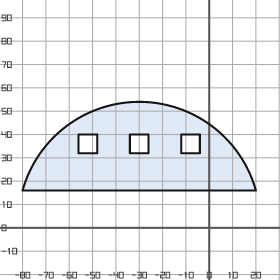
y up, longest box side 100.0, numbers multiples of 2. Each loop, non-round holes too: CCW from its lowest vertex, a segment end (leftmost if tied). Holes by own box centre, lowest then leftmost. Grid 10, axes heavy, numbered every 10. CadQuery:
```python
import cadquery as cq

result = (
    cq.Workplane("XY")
    .moveTo(-80.0, 16.0)
    .lineTo(20.0, 16.0)
    .threePointArc((-30.0, 54.0), (-80.0, 16.0))
    .close()
    .moveTo(-56.0, 32.0)
    .lineTo(-48.0, 32.0)
    .lineTo(-48.0, 40.0)
    .lineTo(-56.0, 40.0)
    .close()
    .moveTo(-34.0, 32.0)
    .lineTo(-26.0, 32.0)
    .lineTo(-26.0, 40.0)
    .lineTo(-34.0, 40.0)
    .close()
    .moveTo(-12.0, 32.0)
    .lineTo(-4.0, 32.0)
    .lineTo(-4.0, 40.0)
    .lineTo(-12.0, 40.0)
    .close()
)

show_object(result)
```